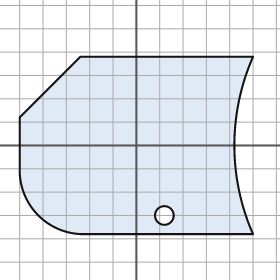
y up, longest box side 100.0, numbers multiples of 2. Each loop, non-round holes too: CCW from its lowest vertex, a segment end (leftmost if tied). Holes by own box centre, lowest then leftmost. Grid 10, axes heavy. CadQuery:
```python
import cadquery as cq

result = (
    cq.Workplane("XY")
    .moveTo(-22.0, -38.0)
    .lineTo(50.0, -38.0)
    .threePointArc((42.0, 0.0), (50.0, 38.0))
    .lineTo(-24.0, 38.0)
    .lineTo(-50.0, 12.0)
    .lineTo(-50.0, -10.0)
    .threePointArc((-42.0, -30.0), (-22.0, -38.0))
    .close()
    .moveTo(12.0, -30.0)
    .circle(4.0)
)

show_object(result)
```